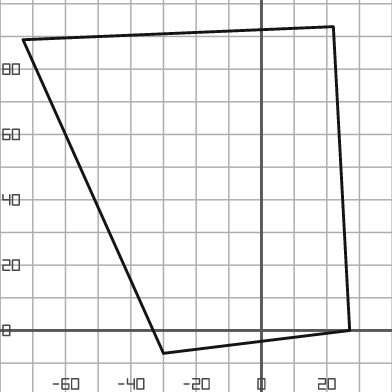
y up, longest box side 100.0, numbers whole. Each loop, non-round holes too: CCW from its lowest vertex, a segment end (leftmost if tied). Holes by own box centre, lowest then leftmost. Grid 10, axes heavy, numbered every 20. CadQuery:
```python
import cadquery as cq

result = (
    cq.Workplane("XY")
    .moveTo(-30.0, -7.0)
    .lineTo(27.0, 0.0)
    .lineTo(22.0, 93.0)
    .lineTo(-73.0, 89.0)
    .close()
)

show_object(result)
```